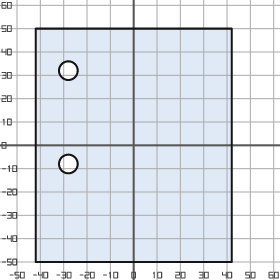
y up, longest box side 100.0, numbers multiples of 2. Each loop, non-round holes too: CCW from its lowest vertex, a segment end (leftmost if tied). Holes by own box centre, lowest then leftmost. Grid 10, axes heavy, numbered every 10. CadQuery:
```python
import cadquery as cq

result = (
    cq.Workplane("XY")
    .moveTo(-42.0, -50.0)
    .lineTo(42.0, -50.0)
    .lineTo(42.0, 50.0)
    .lineTo(-42.0, 50.0)
    .close()
    .moveTo(-28.0, -8.0)
    .circle(4.0)
    .moveTo(-28.0, 32.0)
    .circle(4.0)
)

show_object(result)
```